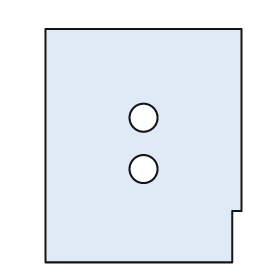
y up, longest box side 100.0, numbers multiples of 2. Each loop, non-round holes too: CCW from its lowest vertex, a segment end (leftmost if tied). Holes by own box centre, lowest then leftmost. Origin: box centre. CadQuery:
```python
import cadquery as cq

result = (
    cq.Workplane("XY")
    .moveTo(-42.0, -50.0)
    .lineTo(38.0, -50.0)
    .lineTo(38.0, -28.0)
    .lineTo(42.0, -28.0)
    .lineTo(42.0, 50.0)
    .lineTo(-42.0, 50.0)
    .close()
    .moveTo(0.0, -10.0)
    .circle(6.0)
    .moveTo(0.0, 12.0)
    .circle(6.0)
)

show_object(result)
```